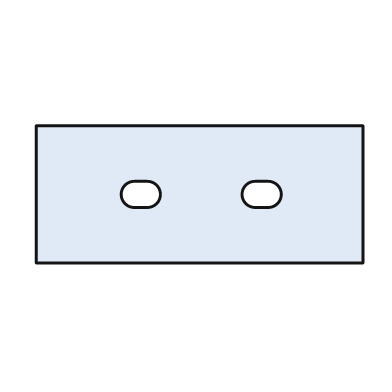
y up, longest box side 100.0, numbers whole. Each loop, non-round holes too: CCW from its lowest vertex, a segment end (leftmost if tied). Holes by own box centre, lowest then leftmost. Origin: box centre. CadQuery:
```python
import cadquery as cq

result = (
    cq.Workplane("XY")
    .moveTo(-50.0, -21.0)
    .lineTo(50.0, -21.0)
    .lineTo(50.0, 21.0)
    .lineTo(-50.0, 21.0)
    .close()
    .moveTo(-20.0, -4.0)
    .lineTo(-16.0, -4.0)
    .threePointArc((-12.0, 0.0), (-16.0, 4.0))
    .lineTo(-20.0, 4.0)
    .threePointArc((-24.0, 0.0), (-20.0, -4.0))
    .close()
    .moveTo(17.0, -4.0)
    .lineTo(21.0, -4.0)
    .threePointArc((25.0, 0.0), (21.0, 4.0))
    .lineTo(17.0, 4.0)
    .threePointArc((13.0, 0.0), (17.0, -4.0))
    .close()
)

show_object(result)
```